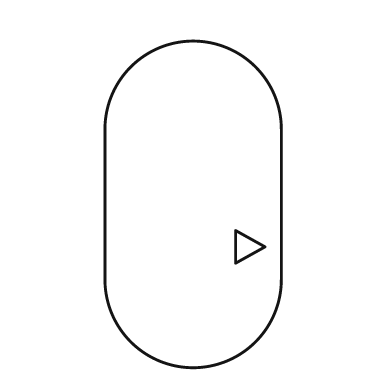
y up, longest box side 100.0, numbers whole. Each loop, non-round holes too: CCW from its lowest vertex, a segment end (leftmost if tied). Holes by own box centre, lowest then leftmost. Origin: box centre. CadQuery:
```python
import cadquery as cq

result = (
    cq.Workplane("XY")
    .moveTo(-27.0, -23.0)
    .threePointArc((0.0, -50.0), (27.0, -23.0))
    .lineTo(27.0, 23.0)
    .threePointArc((0.0, 50.0), (-27.0, 23.0))
    .close()
    .moveTo(13.0, -18.0)
    .lineTo(22.0, -13.0)
    .lineTo(13.0, -8.0)
    .close()
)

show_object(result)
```